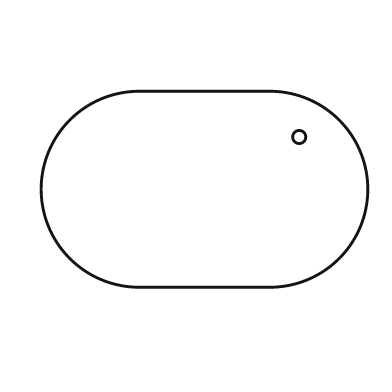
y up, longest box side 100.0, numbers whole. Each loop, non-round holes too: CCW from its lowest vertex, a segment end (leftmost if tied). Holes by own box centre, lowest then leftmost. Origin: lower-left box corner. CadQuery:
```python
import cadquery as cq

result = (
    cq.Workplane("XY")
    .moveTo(30.0, 0.0)
    .lineTo(70.0, 0.0)
    .threePointArc((100.0, 30.0), (70.0, 60.0))
    .lineTo(30.0, 60.0)
    .threePointArc((0.0, 30.0), (30.0, 0.0))
    .close()
    .moveTo(79.0, 46.0)
    .circle(2.0)
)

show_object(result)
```